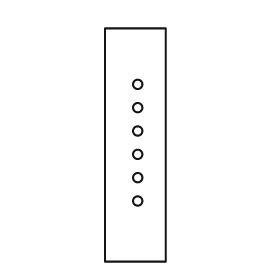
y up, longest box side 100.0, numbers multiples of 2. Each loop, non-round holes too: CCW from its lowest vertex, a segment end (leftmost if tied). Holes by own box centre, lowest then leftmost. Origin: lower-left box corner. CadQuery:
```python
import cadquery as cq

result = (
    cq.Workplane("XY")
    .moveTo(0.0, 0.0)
    .lineTo(26.0, 0.0)
    .lineTo(26.0, 100.0)
    .lineTo(0.0, 100.0)
    .close()
    .moveTo(14.0, 26.0)
    .circle(2.0)
    .moveTo(14.0, 36.0)
    .circle(2.0)
    .moveTo(14.0, 46.0)
    .circle(2.0)
    .moveTo(14.0, 56.0)
    .circle(2.0)
    .moveTo(14.0, 66.0)
    .circle(2.0)
    .moveTo(14.0, 76.0)
    .circle(2.0)
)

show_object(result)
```